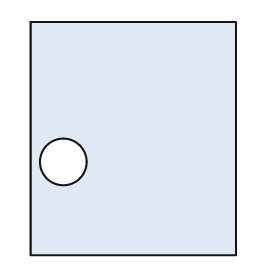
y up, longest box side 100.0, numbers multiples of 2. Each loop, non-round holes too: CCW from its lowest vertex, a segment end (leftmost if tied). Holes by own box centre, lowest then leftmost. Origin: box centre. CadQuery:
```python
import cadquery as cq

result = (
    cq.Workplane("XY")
    .moveTo(-44.0, -50.0)
    .lineTo(44.0, -50.0)
    .lineTo(44.0, 50.0)
    .lineTo(-44.0, 50.0)
    .close()
    .moveTo(-30.0, -10.0)
    .circle(10.0)
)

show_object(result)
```